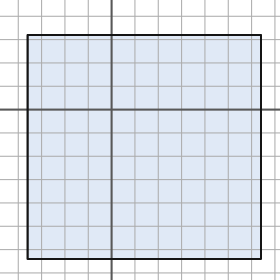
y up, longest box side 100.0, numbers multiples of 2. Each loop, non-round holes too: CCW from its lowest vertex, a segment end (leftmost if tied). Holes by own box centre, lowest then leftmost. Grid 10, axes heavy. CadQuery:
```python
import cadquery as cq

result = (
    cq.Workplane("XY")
    .moveTo(-36.0, -64.0)
    .lineTo(64.0, -64.0)
    .lineTo(64.0, 32.0)
    .lineTo(-36.0, 32.0)
    .close()
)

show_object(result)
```